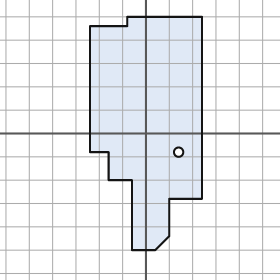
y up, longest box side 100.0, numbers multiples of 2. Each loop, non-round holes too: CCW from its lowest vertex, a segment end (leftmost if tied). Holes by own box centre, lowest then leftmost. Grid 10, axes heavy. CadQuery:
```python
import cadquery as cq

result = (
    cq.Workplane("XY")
    .moveTo(-6.0, -50.0)
    .lineTo(4.0, -50.0)
    .lineTo(10.0, -44.0)
    .lineTo(10.0, -28.0)
    .lineTo(24.0, -28.0)
    .lineTo(24.0, 50.0)
    .lineTo(-8.0, 50.0)
    .lineTo(-8.0, 46.0)
    .lineTo(-24.0, 46.0)
    .lineTo(-24.0, -8.0)
    .lineTo(-16.0, -8.0)
    .lineTo(-16.0, -20.0)
    .lineTo(-6.0, -20.0)
    .close()
    .moveTo(14.0, -8.0)
    .circle(2.0)
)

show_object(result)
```